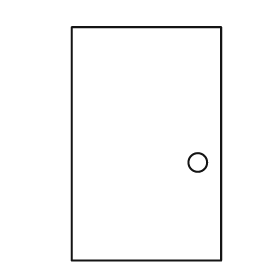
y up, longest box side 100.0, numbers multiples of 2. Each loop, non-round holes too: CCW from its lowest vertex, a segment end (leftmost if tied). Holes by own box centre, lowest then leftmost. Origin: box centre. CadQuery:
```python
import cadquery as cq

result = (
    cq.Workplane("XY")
    .moveTo(-32.0, -50.0)
    .lineTo(32.0, -50.0)
    .lineTo(32.0, 50.0)
    .lineTo(-32.0, 50.0)
    .close()
    .moveTo(22.0, -8.0)
    .circle(4.0)
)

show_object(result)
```